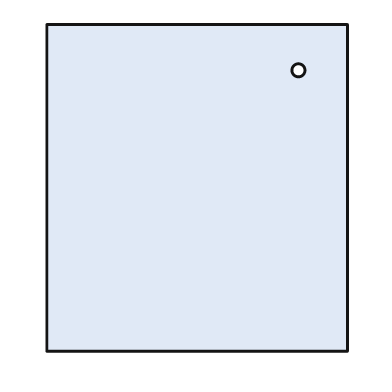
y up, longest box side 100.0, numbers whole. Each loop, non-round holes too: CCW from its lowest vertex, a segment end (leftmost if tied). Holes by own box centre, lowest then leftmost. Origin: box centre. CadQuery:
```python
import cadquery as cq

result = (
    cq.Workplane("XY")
    .moveTo(-46.0, -50.0)
    .lineTo(46.0, -50.0)
    .lineTo(46.0, 50.0)
    .lineTo(-46.0, 50.0)
    .close()
    .moveTo(31.0, 36.0)
    .circle(2.0)
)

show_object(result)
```